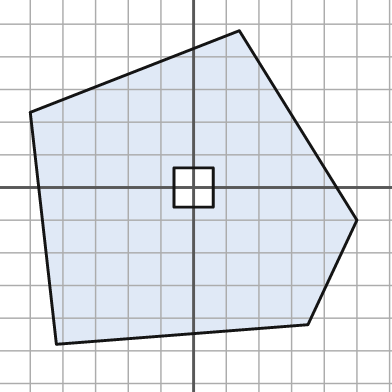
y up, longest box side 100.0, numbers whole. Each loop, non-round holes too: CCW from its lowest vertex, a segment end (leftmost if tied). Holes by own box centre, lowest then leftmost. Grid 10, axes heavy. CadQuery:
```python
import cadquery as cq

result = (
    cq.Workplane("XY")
    .moveTo(-42.0, -48.0)
    .lineTo(35.0, -42.0)
    .lineTo(50.0, -10.0)
    .lineTo(14.0, 48.0)
    .lineTo(-50.0, 23.0)
    .close()
    .moveTo(-6.0, -6.0)
    .lineTo(6.0, -6.0)
    .lineTo(6.0, 6.0)
    .lineTo(-6.0, 6.0)
    .close()
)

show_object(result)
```